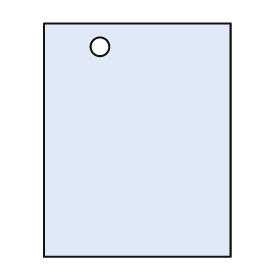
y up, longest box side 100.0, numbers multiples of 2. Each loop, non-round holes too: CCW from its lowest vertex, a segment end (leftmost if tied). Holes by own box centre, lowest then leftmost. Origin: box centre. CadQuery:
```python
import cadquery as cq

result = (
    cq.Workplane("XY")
    .moveTo(-40.0, -50.0)
    .lineTo(40.0, -50.0)
    .lineTo(40.0, 50.0)
    .lineTo(-40.0, 50.0)
    .close()
    .moveTo(-16.0, 40.0)
    .circle(4.0)
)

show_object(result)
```